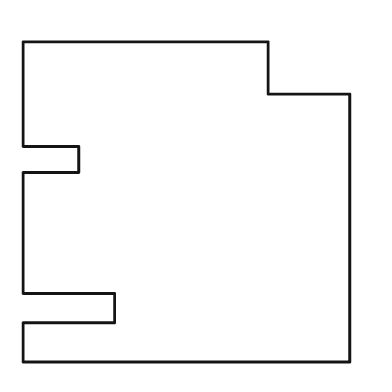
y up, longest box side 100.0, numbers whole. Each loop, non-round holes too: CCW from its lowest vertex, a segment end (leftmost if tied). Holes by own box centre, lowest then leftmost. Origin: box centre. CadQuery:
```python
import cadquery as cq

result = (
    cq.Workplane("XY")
    .moveTo(-50.0, -49.0)
    .lineTo(50.0, -49.0)
    .lineTo(50.0, 33.0)
    .lineTo(25.0, 33.0)
    .lineTo(25.0, 49.0)
    .lineTo(-50.0, 49.0)
    .lineTo(-50.0, 17.0)
    .lineTo(-33.0, 17.0)
    .lineTo(-33.0, 9.0)
    .lineTo(-50.0, 9.0)
    .lineTo(-50.0, -28.0)
    .lineTo(-22.0, -28.0)
    .lineTo(-22.0, -37.0)
    .lineTo(-50.0, -37.0)
    .close()
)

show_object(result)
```